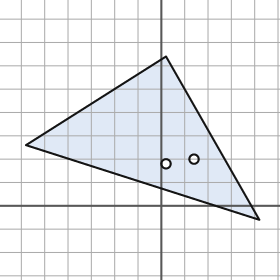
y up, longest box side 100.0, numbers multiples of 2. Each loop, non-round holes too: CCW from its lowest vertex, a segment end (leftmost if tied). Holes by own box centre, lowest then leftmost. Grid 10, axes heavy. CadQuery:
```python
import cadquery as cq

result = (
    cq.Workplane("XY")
    .moveTo(42.0, -6.0)
    .lineTo(2.0, 64.0)
    .lineTo(-58.0, 26.0)
    .close()
    .moveTo(2.0, 18.0)
    .circle(2.0)
    .moveTo(14.0, 20.0)
    .circle(2.0)
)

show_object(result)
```